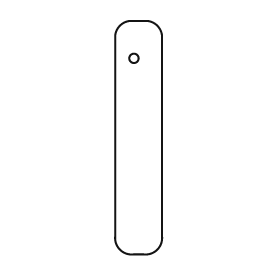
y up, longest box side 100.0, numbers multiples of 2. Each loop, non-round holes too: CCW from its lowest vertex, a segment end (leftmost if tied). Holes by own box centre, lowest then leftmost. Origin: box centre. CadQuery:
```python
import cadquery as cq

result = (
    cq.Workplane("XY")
    .moveTo(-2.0, -50.0)
    .lineTo(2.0, -50.0)
    .threePointArc((8.0, -48.0), (10.0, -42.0))
    .lineTo(10.0, 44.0)
    .threePointArc((8.0, 48.0), (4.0, 50.0))
    .lineTo(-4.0, 50.0)
    .threePointArc((-8.0, 48.0), (-10.0, 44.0))
    .lineTo(-10.0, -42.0)
    .threePointArc((-8.0, -48.0), (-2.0, -50.0))
    .close()
    .moveTo(-2.0, 34.0)
    .circle(2.0)
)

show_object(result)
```